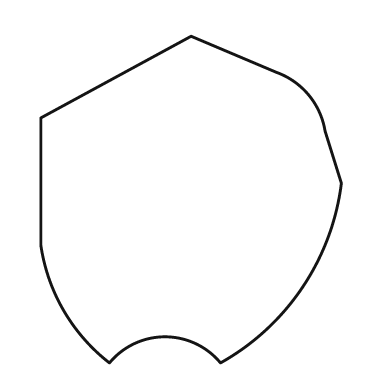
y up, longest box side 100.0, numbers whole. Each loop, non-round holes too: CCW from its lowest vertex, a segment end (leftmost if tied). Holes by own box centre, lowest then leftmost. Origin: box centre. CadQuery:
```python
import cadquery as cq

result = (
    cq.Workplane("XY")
    .moveTo(-25.0, -50.0)
    .threePointArc((-8.0, -42.0), (9.0, -50.0))
    .threePointArc((34.0, -27.0), (46.0, 5.0))
    .lineTo(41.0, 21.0)
    .threePointArc((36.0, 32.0), (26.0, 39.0))
    .lineTo(0.0, 50.0)
    .lineTo(-46.0, 25.0)
    .lineTo(-46.0, -14.0)
    .threePointArc((-39.0, -34.0), (-25.0, -50.0))
    .close()
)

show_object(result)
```